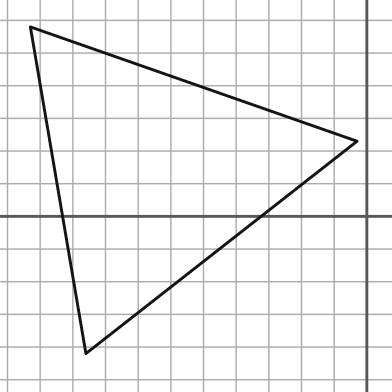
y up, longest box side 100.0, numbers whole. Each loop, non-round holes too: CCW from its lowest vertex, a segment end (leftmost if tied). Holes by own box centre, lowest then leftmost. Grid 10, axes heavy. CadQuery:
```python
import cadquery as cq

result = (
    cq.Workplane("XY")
    .moveTo(-86.0, -42.0)
    .lineTo(-3.0, 23.0)
    .lineTo(-103.0, 58.0)
    .close()
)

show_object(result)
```